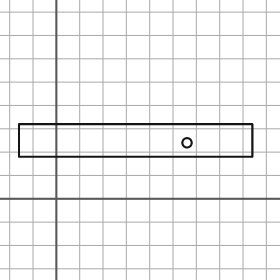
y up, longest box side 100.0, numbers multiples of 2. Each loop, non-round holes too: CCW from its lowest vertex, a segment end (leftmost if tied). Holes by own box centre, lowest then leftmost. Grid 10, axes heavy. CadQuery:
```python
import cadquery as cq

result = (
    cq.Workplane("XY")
    .moveTo(-16.0, 18.0)
    .lineTo(84.0, 18.0)
    .lineTo(84.0, 32.0)
    .lineTo(-16.0, 32.0)
    .close()
    .moveTo(56.0, 24.0)
    .circle(2.0)
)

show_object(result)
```